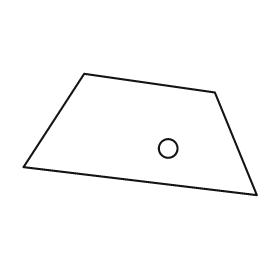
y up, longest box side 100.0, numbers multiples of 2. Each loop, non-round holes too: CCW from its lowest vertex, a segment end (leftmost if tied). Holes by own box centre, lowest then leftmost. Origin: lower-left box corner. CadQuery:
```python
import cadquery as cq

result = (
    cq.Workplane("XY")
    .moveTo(100.0, 0.0)
    .lineTo(82.0, 44.0)
    .lineTo(26.0, 52.0)
    .lineTo(0.0, 12.0)
    .close()
    .moveTo(62.0, 20.0)
    .circle(4.0)
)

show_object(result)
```